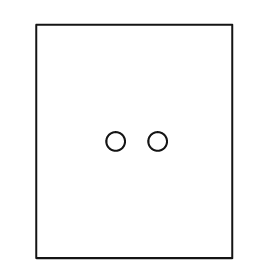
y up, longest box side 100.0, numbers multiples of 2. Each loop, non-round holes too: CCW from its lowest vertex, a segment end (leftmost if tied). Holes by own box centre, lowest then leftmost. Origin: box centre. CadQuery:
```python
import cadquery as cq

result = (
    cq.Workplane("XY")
    .moveTo(-42.0, -50.0)
    .lineTo(42.0, -50.0)
    .lineTo(42.0, 50.0)
    .lineTo(-42.0, 50.0)
    .close()
    .moveTo(-8.0, 0.0)
    .circle(4.0)
    .moveTo(10.0, 0.0)
    .circle(4.0)
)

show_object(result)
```